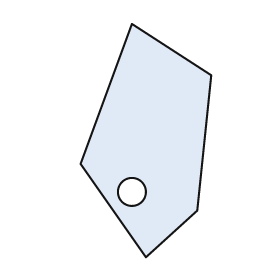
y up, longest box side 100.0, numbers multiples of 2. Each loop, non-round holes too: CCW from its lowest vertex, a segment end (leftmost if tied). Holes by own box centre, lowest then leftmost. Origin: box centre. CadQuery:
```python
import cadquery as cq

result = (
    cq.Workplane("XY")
    .moveTo(0.0, -50.0)
    .lineTo(22.0, -30.0)
    .lineTo(28.0, 28.0)
    .lineTo(-6.0, 50.0)
    .lineTo(-28.0, -10.0)
    .close()
    .moveTo(-6.0, -22.0)
    .circle(6.0)
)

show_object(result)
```